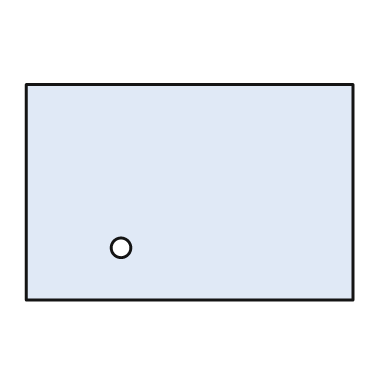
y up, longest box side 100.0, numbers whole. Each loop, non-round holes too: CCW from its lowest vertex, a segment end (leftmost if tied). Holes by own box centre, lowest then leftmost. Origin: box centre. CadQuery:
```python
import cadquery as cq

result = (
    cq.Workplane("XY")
    .moveTo(-50.0, -33.0)
    .lineTo(50.0, -33.0)
    .lineTo(50.0, 33.0)
    .lineTo(-50.0, 33.0)
    .close()
    .moveTo(-21.0, -17.0)
    .circle(3.0)
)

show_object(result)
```